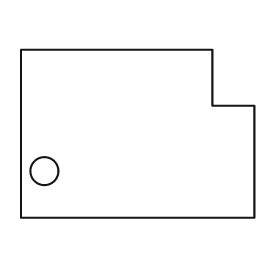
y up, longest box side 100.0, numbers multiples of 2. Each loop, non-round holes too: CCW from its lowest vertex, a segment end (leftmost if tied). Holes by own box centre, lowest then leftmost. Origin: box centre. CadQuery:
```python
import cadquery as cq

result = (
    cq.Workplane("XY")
    .moveTo(-50.0, -36.0)
    .lineTo(50.0, -36.0)
    .lineTo(50.0, 12.0)
    .lineTo(32.0, 12.0)
    .lineTo(32.0, 36.0)
    .lineTo(-50.0, 36.0)
    .close()
    .moveTo(-40.0, -16.0)
    .circle(6.0)
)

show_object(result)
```